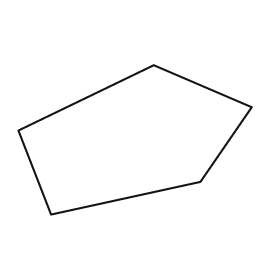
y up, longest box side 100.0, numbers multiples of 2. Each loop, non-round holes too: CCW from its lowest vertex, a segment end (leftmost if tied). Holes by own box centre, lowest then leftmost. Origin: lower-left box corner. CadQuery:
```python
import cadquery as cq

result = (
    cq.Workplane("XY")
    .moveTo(14.0, 0.0)
    .lineTo(78.0, 14.0)
    .lineTo(100.0, 46.0)
    .lineTo(58.0, 64.0)
    .lineTo(0.0, 36.0)
    .close()
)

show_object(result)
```